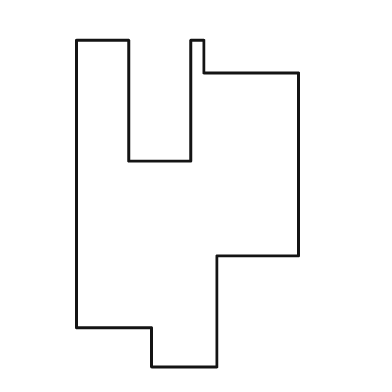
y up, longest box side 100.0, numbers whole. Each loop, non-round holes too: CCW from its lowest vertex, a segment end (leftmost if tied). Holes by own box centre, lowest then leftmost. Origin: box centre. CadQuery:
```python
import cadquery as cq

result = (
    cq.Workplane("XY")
    .moveTo(-11.0, -50.0)
    .lineTo(9.0, -50.0)
    .lineTo(9.0, -16.0)
    .lineTo(34.0, -16.0)
    .lineTo(34.0, 40.0)
    .lineTo(5.0, 40.0)
    .lineTo(5.0, 50.0)
    .lineTo(1.0, 50.0)
    .lineTo(1.0, 13.0)
    .lineTo(-18.0, 13.0)
    .lineTo(-18.0, 50.0)
    .lineTo(-34.0, 50.0)
    .lineTo(-34.0, -38.0)
    .lineTo(-11.0, -38.0)
    .close()
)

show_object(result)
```